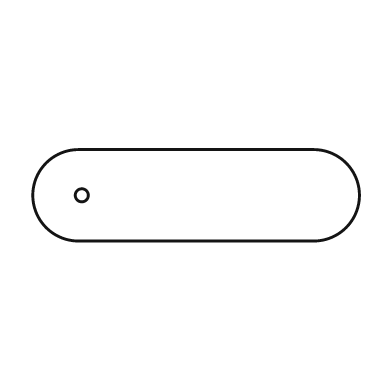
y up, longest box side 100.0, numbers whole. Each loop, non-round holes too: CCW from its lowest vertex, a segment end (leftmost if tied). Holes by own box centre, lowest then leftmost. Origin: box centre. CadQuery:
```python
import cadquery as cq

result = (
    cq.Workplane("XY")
    .moveTo(-36.0, -14.0)
    .lineTo(36.0, -14.0)
    .threePointArc((50.0, 0.0), (36.0, 14.0))
    .lineTo(-36.0, 14.0)
    .threePointArc((-50.0, 0.0), (-36.0, -14.0))
    .close()
    .moveTo(-35.0, 0.0)
    .circle(2.0)
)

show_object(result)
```